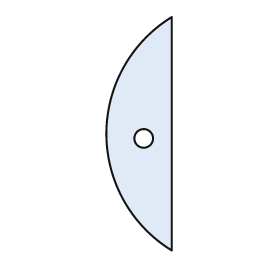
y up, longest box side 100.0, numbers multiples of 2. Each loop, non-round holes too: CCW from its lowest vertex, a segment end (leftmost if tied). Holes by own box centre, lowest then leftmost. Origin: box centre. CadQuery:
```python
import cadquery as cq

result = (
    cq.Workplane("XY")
    .moveTo(14.0, -50.0)
    .lineTo(14.0, 50.0)
    .threePointArc((-14.0, 0.0), (14.0, -50.0))
    .close()
    .moveTo(2.0, -2.0)
    .circle(4.0)
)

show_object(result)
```